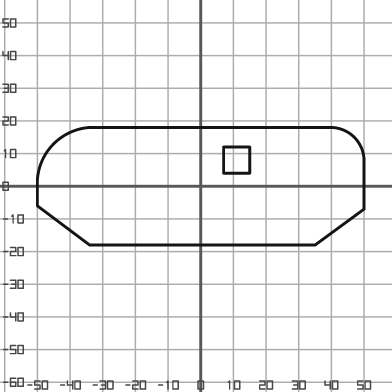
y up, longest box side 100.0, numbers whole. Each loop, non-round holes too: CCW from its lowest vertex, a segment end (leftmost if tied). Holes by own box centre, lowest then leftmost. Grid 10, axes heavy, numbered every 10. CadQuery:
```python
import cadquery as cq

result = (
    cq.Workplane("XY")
    .moveTo(-34.0, -18.0)
    .lineTo(35.0, -18.0)
    .lineTo(50.0, -7.0)
    .lineTo(50.0, 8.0)
    .threePointArc((47.0, 15.0), (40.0, 18.0))
    .lineTo(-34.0, 18.0)
    .threePointArc((-45.0, 13.0), (-50.0, 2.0))
    .lineTo(-50.0, -6.0)
    .close()
    .moveTo(7.0, 4.0)
    .lineTo(15.0, 4.0)
    .lineTo(15.0, 12.0)
    .lineTo(7.0, 12.0)
    .close()
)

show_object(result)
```